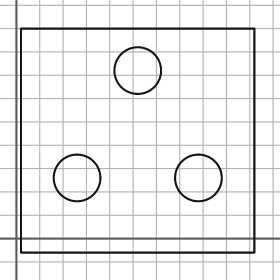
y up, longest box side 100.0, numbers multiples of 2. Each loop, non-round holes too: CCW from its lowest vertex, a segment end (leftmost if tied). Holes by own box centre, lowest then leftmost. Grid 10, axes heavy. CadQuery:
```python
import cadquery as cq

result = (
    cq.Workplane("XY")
    .moveTo(2.0, -6.0)
    .lineTo(102.0, -6.0)
    .lineTo(102.0, 90.0)
    .lineTo(2.0, 90.0)
    .close()
    .moveTo(26.0, 26.0)
    .circle(10.0)
    .moveTo(78.0, 26.0)
    .circle(10.0)
    .moveTo(52.0, 72.0)
    .circle(10.0)
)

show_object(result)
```